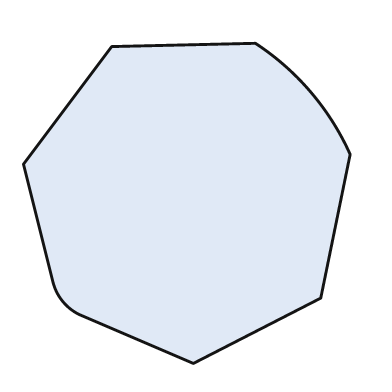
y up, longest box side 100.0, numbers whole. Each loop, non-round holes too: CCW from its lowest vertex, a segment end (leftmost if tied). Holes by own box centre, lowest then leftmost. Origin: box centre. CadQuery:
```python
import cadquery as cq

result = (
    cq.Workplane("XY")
    .moveTo(2.0, -49.0)
    .lineTo(41.0, -29.0)
    .lineTo(50.0, 15.0)
    .threePointArc((38.0, 34.0), (21.0, 49.0))
    .lineTo(-23.0, 48.0)
    .lineTo(-50.0, 12.0)
    .lineTo(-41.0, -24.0)
    .threePointArc((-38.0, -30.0), (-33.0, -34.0))
    .close()
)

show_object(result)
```